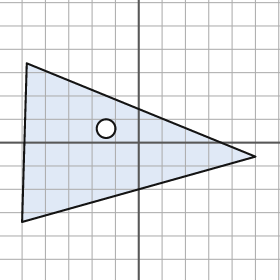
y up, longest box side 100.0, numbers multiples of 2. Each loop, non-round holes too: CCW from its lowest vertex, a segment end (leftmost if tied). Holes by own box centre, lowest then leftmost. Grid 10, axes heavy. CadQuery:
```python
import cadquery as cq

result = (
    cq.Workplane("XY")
    .moveTo(-50.0, -34.0)
    .lineTo(50.0, -6.0)
    .lineTo(-48.0, 34.0)
    .close()
    .moveTo(-14.0, 6.0)
    .circle(4.0)
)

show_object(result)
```